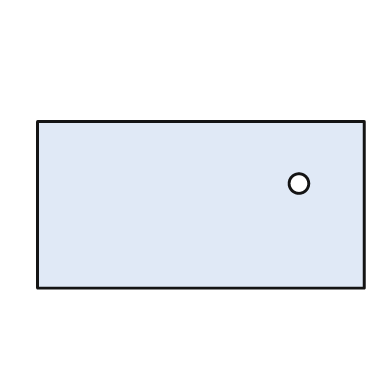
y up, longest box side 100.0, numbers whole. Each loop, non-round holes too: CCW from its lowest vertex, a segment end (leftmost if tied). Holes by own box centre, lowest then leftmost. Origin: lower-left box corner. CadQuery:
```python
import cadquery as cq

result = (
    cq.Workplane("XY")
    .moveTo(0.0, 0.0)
    .lineTo(100.0, 0.0)
    .lineTo(100.0, 51.0)
    .lineTo(0.0, 51.0)
    .close()
    .moveTo(80.0, 32.0)
    .circle(3.0)
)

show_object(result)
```